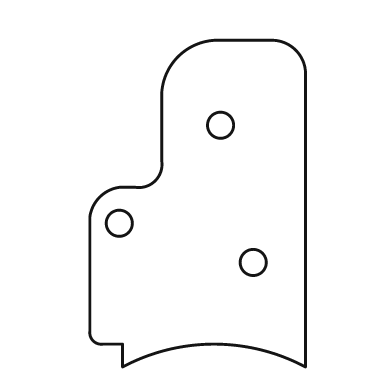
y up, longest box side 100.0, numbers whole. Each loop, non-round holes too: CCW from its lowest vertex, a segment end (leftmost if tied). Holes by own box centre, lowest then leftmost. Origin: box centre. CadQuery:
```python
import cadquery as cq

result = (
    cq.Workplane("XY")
    .moveTo(-23.0, -50.0)
    .threePointArc((5.0, -43.0), (33.0, -50.0))
    .lineTo(33.0, 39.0)
    .threePointArc((30.0, 47.0), (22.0, 50.0))
    .lineTo(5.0, 50.0)
    .threePointArc((-6.0, 45.0), (-11.0, 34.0))
    .lineTo(-11.0, 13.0)
    .threePointArc((-13.0, 7.0), (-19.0, 5.0))
    .lineTo(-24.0, 5.0)
    .threePointArc((-30.0, 2.0), (-33.0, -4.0))
    .lineTo(-33.0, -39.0)
    .threePointArc((-32.0, -42.0), (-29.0, -43.0))
    .lineTo(-23.0, -43.0)
    .close()
    .moveTo(17.0, -18.0)
    .circle(4.0)
    .moveTo(-24.0, -6.0)
    .circle(4.0)
    .moveTo(7.0, 24.0)
    .circle(4.0)
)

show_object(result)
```